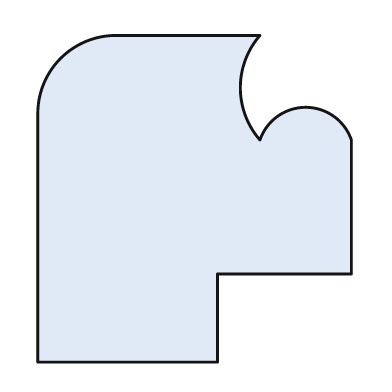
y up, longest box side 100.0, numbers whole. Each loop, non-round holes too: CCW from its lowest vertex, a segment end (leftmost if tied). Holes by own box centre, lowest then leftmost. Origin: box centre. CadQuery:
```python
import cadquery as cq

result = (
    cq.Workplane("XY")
    .moveTo(-48.0, -50.0)
    .lineTo(7.0, -50.0)
    .lineTo(7.0, -23.0)
    .lineTo(48.0, -23.0)
    .lineTo(48.0, 18.0)
    .threePointArc((34.0, 28.0), (20.0, 18.0))
    .threePointArc((14.0, 34.0), (20.0, 50.0))
    .lineTo(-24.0, 50.0)
    .threePointArc((-41.0, 43.0), (-48.0, 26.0))
    .close()
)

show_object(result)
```